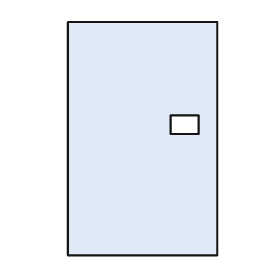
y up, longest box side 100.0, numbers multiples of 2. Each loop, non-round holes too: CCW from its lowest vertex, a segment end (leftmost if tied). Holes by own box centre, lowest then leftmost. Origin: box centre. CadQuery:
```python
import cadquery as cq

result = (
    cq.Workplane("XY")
    .moveTo(-32.0, -50.0)
    .lineTo(32.0, -50.0)
    .lineTo(32.0, 50.0)
    .lineTo(-32.0, 50.0)
    .close()
    .moveTo(12.0, 2.0)
    .lineTo(24.0, 2.0)
    .lineTo(24.0, 10.0)
    .lineTo(12.0, 10.0)
    .close()
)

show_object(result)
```